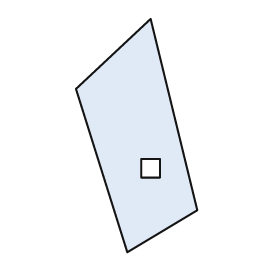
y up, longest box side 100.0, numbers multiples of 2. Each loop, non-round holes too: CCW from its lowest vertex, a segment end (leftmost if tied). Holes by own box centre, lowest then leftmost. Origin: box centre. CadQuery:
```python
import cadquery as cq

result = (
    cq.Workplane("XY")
    .moveTo(-4.0, -50.0)
    .lineTo(26.0, -32.0)
    .lineTo(6.0, 50.0)
    .lineTo(-26.0, 20.0)
    .close()
    .moveTo(2.0, -18.0)
    .lineTo(10.0, -18.0)
    .lineTo(10.0, -10.0)
    .lineTo(2.0, -10.0)
    .close()
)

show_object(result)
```